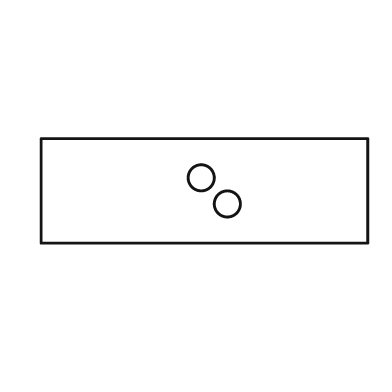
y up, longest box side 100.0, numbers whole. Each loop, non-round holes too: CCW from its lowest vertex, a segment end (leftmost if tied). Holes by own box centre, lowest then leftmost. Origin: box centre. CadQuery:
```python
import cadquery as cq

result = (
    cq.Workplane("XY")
    .moveTo(-50.0, -16.0)
    .lineTo(50.0, -16.0)
    .lineTo(50.0, 16.0)
    .lineTo(-50.0, 16.0)
    .close()
    .moveTo(7.0, -4.0)
    .circle(4.0)
    .moveTo(-1.0, 4.0)
    .circle(4.0)
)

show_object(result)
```